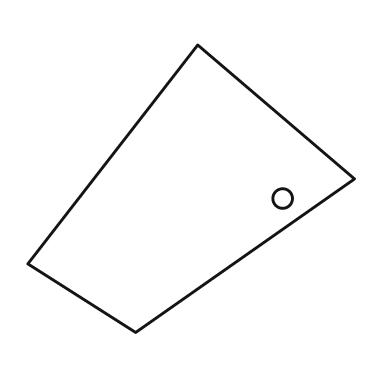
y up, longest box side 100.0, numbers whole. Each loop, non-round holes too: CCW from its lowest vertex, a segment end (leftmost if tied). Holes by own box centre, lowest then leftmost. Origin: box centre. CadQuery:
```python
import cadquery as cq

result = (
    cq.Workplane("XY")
    .moveTo(-17.0, -44.0)
    .lineTo(50.0, 3.0)
    .lineTo(2.0, 44.0)
    .lineTo(-50.0, -23.0)
    .close()
    .moveTo(28.0, -3.0)
    .circle(3.0)
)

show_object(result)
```